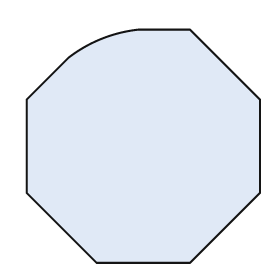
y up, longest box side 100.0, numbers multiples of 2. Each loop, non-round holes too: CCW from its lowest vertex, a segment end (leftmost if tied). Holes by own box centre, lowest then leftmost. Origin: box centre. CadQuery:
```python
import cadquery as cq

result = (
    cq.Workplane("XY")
    .moveTo(-20.0, -50.0)
    .lineTo(20.0, -50.0)
    .lineTo(50.0, -20.0)
    .lineTo(50.0, 20.0)
    .lineTo(20.0, 50.0)
    .lineTo(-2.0, 50.0)
    .threePointArc((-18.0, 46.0), (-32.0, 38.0))
    .lineTo(-50.0, 20.0)
    .lineTo(-50.0, -20.0)
    .close()
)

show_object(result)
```